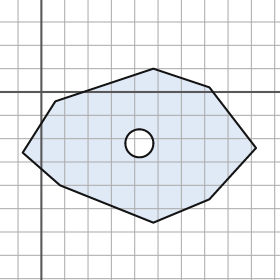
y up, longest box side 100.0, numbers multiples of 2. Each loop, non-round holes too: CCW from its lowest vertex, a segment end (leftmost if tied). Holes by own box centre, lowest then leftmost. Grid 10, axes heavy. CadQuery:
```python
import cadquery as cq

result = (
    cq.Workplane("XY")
    .moveTo(48.0, -56.0)
    .lineTo(72.0, -46.0)
    .lineTo(92.0, -24.0)
    .lineTo(72.0, 2.0)
    .lineTo(48.0, 10.0)
    .lineTo(6.0, -4.0)
    .lineTo(-8.0, -26.0)
    .lineTo(8.0, -40.0)
    .close()
    .moveTo(42.0, -22.0)
    .circle(6.0)
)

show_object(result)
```